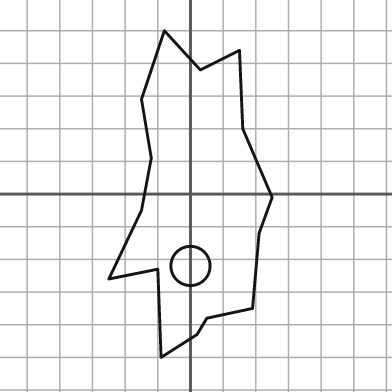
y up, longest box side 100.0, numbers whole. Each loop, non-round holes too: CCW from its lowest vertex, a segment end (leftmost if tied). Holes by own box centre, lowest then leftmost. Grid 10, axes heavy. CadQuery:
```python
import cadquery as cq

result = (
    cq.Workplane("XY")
    .moveTo(-9.0, -50.0)
    .lineTo(2.0, -43.0)
    .lineTo(5.0, -38.0)
    .lineTo(19.0, -35.0)
    .lineTo(21.0, -12.0)
    .lineTo(25.0, -1.0)
    .lineTo(16.0, 20.0)
    .lineTo(15.0, 44.0)
    .lineTo(3.0, 38.0)
    .lineTo(-8.0, 50.0)
    .lineTo(-15.0, 29.0)
    .lineTo(-12.0, 11.0)
    .lineTo(-15.0, -5.0)
    .lineTo(-25.0, -26.0)
    .lineTo(-10.0, -23.0)
    .close()
    .moveTo(0.0, -22.0)
    .circle(6.0)
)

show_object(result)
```